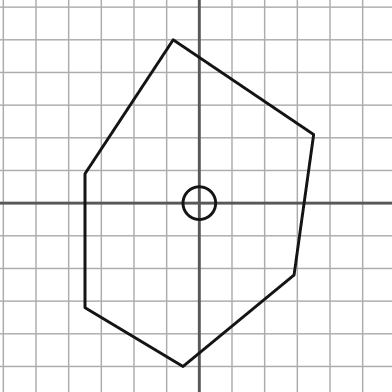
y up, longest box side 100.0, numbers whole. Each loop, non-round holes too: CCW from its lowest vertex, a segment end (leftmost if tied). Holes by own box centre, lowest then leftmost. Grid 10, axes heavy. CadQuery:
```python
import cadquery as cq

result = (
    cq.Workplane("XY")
    .moveTo(-5.0, -50.0)
    .lineTo(29.0, -22.0)
    .lineTo(35.0, 21.0)
    .lineTo(-8.0, 50.0)
    .lineTo(-35.0, 9.0)
    .lineTo(-35.0, -32.0)
    .close()
    .moveTo(0.0, 0.0)
    .circle(5.0)
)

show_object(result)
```